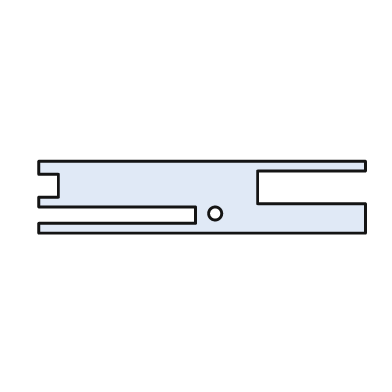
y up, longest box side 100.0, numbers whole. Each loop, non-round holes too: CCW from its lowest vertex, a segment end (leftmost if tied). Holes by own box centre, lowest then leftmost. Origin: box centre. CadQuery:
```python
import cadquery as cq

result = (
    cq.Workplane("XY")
    .moveTo(-50.0, -11.0)
    .lineTo(50.0, -11.0)
    .lineTo(50.0, -2.0)
    .lineTo(17.0, -2.0)
    .lineTo(17.0, 8.0)
    .lineTo(50.0, 8.0)
    .lineTo(50.0, 11.0)
    .lineTo(-50.0, 11.0)
    .lineTo(-50.0, 7.0)
    .lineTo(-44.0, 7.0)
    .lineTo(-44.0, 0.0)
    .lineTo(-50.0, 0.0)
    .lineTo(-50.0, -3.0)
    .lineTo(-2.0, -3.0)
    .lineTo(-2.0, -8.0)
    .lineTo(-50.0, -8.0)
    .close()
    .moveTo(4.0, -5.0)
    .circle(2.0)
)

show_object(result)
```